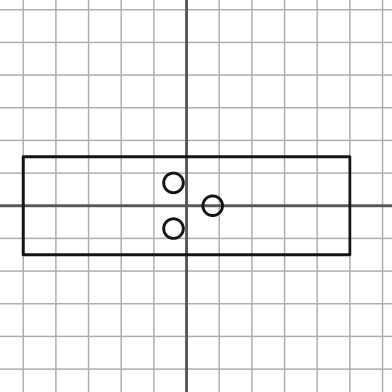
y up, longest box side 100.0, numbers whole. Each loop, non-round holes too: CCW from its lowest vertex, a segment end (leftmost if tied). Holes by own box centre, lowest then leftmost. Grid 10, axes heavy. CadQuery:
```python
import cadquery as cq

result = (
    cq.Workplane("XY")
    .moveTo(-50.0, -15.0)
    .lineTo(50.0, -15.0)
    .lineTo(50.0, 15.0)
    .lineTo(-50.0, 15.0)
    .close()
    .moveTo(-4.0, -7.0)
    .circle(3.0)
    .moveTo(8.0, 0.0)
    .circle(3.0)
    .moveTo(-4.0, 7.0)
    .circle(3.0)
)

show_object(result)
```